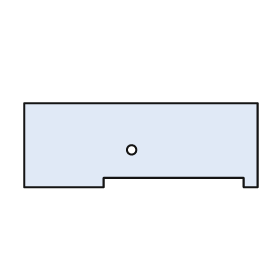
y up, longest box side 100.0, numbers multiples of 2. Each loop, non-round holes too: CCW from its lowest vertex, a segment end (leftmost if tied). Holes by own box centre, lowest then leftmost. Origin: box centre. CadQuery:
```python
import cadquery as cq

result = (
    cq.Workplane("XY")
    .moveTo(-50.0, -18.0)
    .lineTo(-16.0, -18.0)
    .lineTo(-16.0, -14.0)
    .lineTo(44.0, -14.0)
    .lineTo(44.0, -18.0)
    .lineTo(50.0, -18.0)
    .lineTo(50.0, 18.0)
    .lineTo(-50.0, 18.0)
    .close()
    .moveTo(-4.0, -2.0)
    .circle(2.0)
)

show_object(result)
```